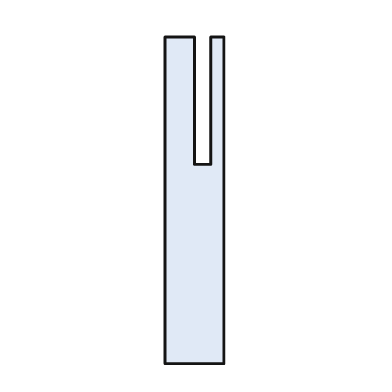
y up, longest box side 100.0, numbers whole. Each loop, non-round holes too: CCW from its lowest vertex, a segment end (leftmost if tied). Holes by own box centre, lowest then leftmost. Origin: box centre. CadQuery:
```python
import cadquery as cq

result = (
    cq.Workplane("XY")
    .moveTo(-9.0, -50.0)
    .lineTo(9.0, -50.0)
    .lineTo(9.0, 50.0)
    .lineTo(5.0, 50.0)
    .lineTo(5.0, 11.0)
    .lineTo(0.0, 11.0)
    .lineTo(0.0, 50.0)
    .lineTo(-9.0, 50.0)
    .close()
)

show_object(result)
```